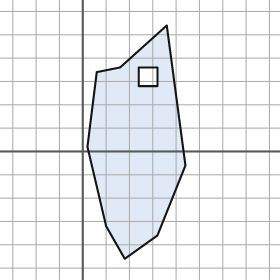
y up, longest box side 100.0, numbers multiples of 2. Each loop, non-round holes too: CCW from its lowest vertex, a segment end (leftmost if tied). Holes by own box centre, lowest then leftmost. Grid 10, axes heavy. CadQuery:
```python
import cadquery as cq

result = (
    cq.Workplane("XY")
    .moveTo(18.0, -46.0)
    .lineTo(32.0, -36.0)
    .lineTo(44.0, -6.0)
    .lineTo(36.0, 54.0)
    .lineTo(16.0, 36.0)
    .lineTo(6.0, 34.0)
    .lineTo(2.0, 2.0)
    .lineTo(10.0, -32.0)
    .close()
    .moveTo(24.0, 28.0)
    .lineTo(32.0, 28.0)
    .lineTo(32.0, 36.0)
    .lineTo(24.0, 36.0)
    .close()
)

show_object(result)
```